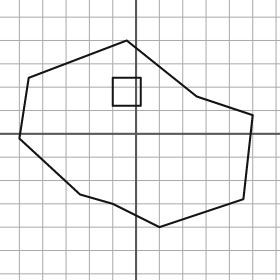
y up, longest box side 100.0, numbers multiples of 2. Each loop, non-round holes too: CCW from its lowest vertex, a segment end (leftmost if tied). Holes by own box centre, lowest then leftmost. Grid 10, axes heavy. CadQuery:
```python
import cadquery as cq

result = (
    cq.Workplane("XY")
    .moveTo(10.0, -40.0)
    .lineTo(46.0, -28.0)
    .lineTo(50.0, 8.0)
    .lineTo(26.0, 16.0)
    .lineTo(-4.0, 40.0)
    .lineTo(-46.0, 24.0)
    .lineTo(-50.0, -2.0)
    .lineTo(-24.0, -26.0)
    .lineTo(-10.0, -30.0)
    .close()
    .moveTo(-10.0, 12.0)
    .lineTo(2.0, 12.0)
    .lineTo(2.0, 24.0)
    .lineTo(-10.0, 24.0)
    .close()
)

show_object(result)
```